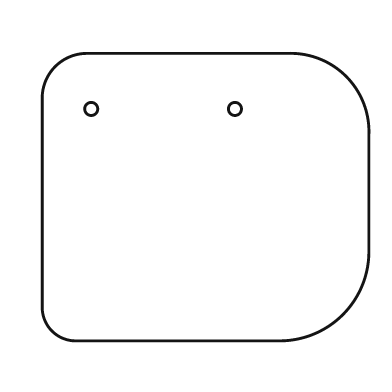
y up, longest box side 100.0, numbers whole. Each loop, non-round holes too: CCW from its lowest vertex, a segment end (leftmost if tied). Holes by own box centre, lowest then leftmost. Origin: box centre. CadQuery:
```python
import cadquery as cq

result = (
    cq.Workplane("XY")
    .moveTo(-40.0, -44.0)
    .lineTo(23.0, -44.0)
    .threePointArc((42.0, -36.0), (50.0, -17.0))
    .lineTo(50.0, 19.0)
    .threePointArc((43.0, 37.0), (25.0, 44.0))
    .lineTo(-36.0, 44.0)
    .threePointArc((-46.0, 40.0), (-50.0, 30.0))
    .lineTo(-50.0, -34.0)
    .threePointArc((-47.0, -41.0), (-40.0, -44.0))
    .close()
    .moveTo(-35.0, 27.0)
    .circle(2.0)
    .moveTo(9.0, 27.0)
    .circle(2.0)
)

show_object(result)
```